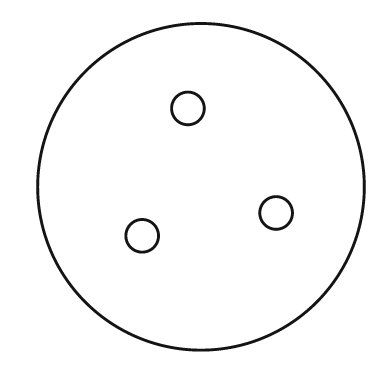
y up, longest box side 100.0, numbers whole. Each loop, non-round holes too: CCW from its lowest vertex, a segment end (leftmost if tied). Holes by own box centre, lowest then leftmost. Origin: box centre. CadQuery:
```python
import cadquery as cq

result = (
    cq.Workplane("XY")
    .moveTo(0.0, 0.0)
    .circle(50.0)
    .moveTo(-18.0, -15.0)
    .circle(5.0)
    .moveTo(23.0, -8.0)
    .circle(5.0)
    .moveTo(-4.0, 24.0)
    .circle(5.0)
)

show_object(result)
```